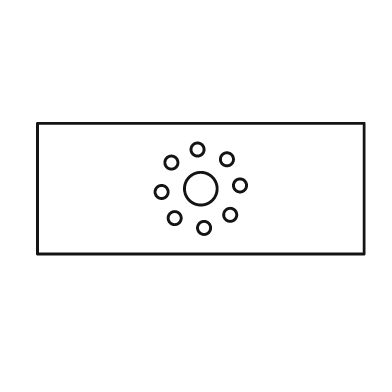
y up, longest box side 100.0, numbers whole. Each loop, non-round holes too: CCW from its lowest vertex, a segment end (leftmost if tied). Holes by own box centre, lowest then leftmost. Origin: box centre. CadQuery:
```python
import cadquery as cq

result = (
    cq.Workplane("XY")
    .moveTo(-50.0, -20.0)
    .lineTo(50.0, -20.0)
    .lineTo(50.0, 20.0)
    .lineTo(-50.0, 20.0)
    .close()
    .moveTo(1.0, -12.0)
    .circle(2.0)
    .moveTo(-8.0, -9.0)
    .circle(2.0)
    .moveTo(9.0, -8.0)
    .circle(2.0)
    .moveTo(-12.0, -1.0)
    .circle(2.0)
    .moveTo(0.0, 0.0)
    .circle(5.0)
    .moveTo(12.0, 1.0)
    .circle(2.0)
    .moveTo(-9.0, 8.0)
    .circle(2.0)
    .moveTo(8.0, 9.0)
    .circle(2.0)
    .moveTo(-1.0, 12.0)
    .circle(2.0)
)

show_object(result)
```